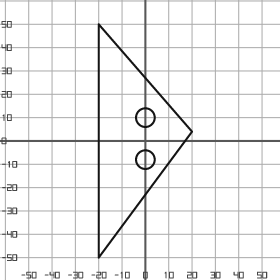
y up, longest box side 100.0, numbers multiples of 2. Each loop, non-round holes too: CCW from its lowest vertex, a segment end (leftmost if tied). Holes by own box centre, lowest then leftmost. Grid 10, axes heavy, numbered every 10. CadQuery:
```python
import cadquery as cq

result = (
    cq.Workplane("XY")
    .moveTo(-20.0, -50.0)
    .lineTo(20.0, 4.0)
    .lineTo(-20.0, 50.0)
    .close()
    .moveTo(0.0, -8.0)
    .circle(4.0)
    .moveTo(0.0, 10.0)
    .circle(4.0)
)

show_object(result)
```